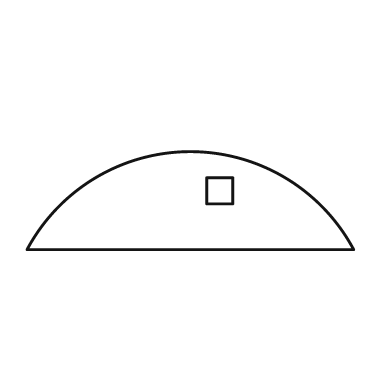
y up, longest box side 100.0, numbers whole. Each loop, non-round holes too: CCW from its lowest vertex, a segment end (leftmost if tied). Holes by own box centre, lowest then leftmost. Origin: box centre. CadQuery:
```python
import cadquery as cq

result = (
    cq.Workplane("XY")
    .moveTo(-50.0, -15.0)
    .lineTo(50.0, -15.0)
    .threePointArc((0.0, 15.0), (-50.0, -15.0))
    .close()
    .moveTo(5.0, -1.0)
    .lineTo(13.0, -1.0)
    .lineTo(13.0, 7.0)
    .lineTo(5.0, 7.0)
    .close()
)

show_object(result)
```